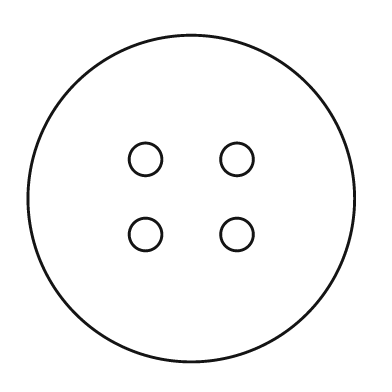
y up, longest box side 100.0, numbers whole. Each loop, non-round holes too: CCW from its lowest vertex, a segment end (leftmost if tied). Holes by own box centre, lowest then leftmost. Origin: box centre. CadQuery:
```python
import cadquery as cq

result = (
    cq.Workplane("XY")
    .moveTo(0.0, 0.0)
    .circle(50.0)
    .moveTo(-14.0, -11.0)
    .circle(5.0)
    .moveTo(14.0, -11.0)
    .circle(5.0)
    .moveTo(-14.0, 12.0)
    .circle(5.0)
    .moveTo(14.0, 12.0)
    .circle(5.0)
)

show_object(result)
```